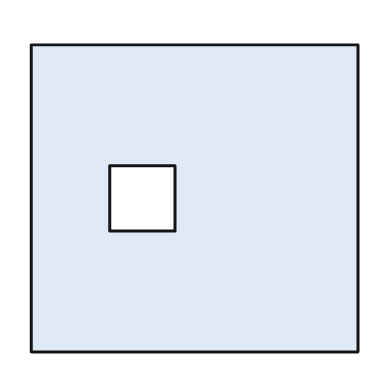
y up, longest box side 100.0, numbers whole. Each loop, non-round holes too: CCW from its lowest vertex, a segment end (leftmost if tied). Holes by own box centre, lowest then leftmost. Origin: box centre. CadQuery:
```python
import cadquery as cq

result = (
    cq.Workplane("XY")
    .moveTo(-50.0, -47.0)
    .lineTo(50.0, -47.0)
    .lineTo(50.0, 47.0)
    .lineTo(-50.0, 47.0)
    .close()
    .moveTo(-26.0, -10.0)
    .lineTo(-6.0, -10.0)
    .lineTo(-6.0, 10.0)
    .lineTo(-26.0, 10.0)
    .close()
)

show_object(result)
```